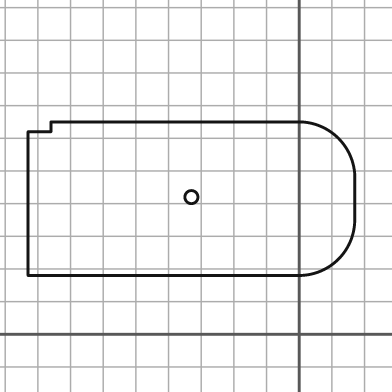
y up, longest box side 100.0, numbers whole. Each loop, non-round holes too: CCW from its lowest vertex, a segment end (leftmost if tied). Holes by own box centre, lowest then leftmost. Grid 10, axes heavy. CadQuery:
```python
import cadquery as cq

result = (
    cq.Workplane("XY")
    .moveTo(-83.0, 18.0)
    .lineTo(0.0, 18.0)
    .threePointArc((12.0, 23.0), (17.0, 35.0))
    .lineTo(17.0, 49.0)
    .threePointArc((12.0, 60.0), (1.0, 65.0))
    .lineTo(-76.0, 65.0)
    .lineTo(-76.0, 62.0)
    .lineTo(-83.0, 62.0)
    .close()
    .moveTo(-33.0, 42.0)
    .circle(2.0)
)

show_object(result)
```